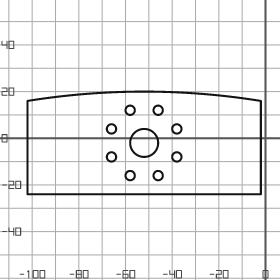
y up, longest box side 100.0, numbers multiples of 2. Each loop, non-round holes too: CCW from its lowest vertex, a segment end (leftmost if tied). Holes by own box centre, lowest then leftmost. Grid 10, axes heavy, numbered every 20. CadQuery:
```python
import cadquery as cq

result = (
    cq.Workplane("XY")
    .moveTo(-102.0, -24.0)
    .lineTo(-2.0, -24.0)
    .lineTo(-2.0, 16.0)
    .threePointArc((-52.0, 20.0), (-102.0, 16.0))
    .close()
    .moveTo(-58.0, -16.0)
    .circle(2.0)
    .moveTo(-46.0, -16.0)
    .circle(2.0)
    .moveTo(-66.0, -8.0)
    .circle(2.0)
    .moveTo(-38.0, -8.0)
    .circle(2.0)
    .moveTo(-52.0, -2.0)
    .circle(6.0)
    .moveTo(-66.0, 4.0)
    .circle(2.0)
    .moveTo(-38.0, 4.0)
    .circle(2.0)
    .moveTo(-58.0, 12.0)
    .circle(2.0)
    .moveTo(-46.0, 12.0)
    .circle(2.0)
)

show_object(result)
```